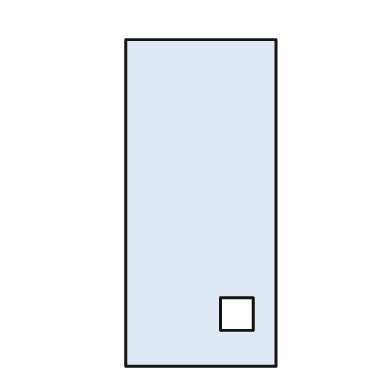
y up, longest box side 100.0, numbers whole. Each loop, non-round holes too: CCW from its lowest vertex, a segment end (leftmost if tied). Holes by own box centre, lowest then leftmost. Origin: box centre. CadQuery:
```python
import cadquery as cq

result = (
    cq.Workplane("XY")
    .moveTo(-23.0, -50.0)
    .lineTo(23.0, -50.0)
    .lineTo(23.0, 50.0)
    .lineTo(-23.0, 50.0)
    .close()
    .moveTo(6.0, -39.0)
    .lineTo(16.0, -39.0)
    .lineTo(16.0, -29.0)
    .lineTo(6.0, -29.0)
    .close()
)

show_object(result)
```